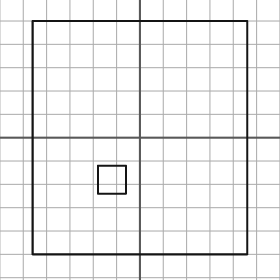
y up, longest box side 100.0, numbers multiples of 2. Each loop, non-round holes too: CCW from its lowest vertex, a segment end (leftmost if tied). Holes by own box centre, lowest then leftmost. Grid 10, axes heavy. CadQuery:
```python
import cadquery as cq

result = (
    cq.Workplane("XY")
    .moveTo(-46.0, -50.0)
    .lineTo(46.0, -50.0)
    .lineTo(46.0, 50.0)
    .lineTo(-46.0, 50.0)
    .close()
    .moveTo(-18.0, -24.0)
    .lineTo(-6.0, -24.0)
    .lineTo(-6.0, -12.0)
    .lineTo(-18.0, -12.0)
    .close()
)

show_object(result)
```